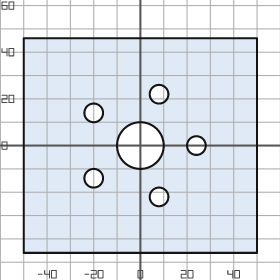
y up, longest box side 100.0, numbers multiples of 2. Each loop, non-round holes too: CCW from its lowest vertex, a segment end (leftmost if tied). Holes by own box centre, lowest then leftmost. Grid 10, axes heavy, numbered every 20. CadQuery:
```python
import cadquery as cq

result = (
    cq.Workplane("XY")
    .moveTo(-50.0, -46.0)
    .lineTo(50.0, -46.0)
    .lineTo(50.0, 46.0)
    .lineTo(-50.0, 46.0)
    .close()
    .moveTo(8.0, -22.0)
    .circle(4.0)
    .moveTo(-20.0, -14.0)
    .circle(4.0)
    .moveTo(0.0, 0.0)
    .circle(10.0)
    .moveTo(24.0, 0.0)
    .circle(4.0)
    .moveTo(-20.0, 14.0)
    .circle(4.0)
    .moveTo(8.0, 22.0)
    .circle(4.0)
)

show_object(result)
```